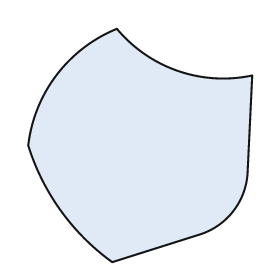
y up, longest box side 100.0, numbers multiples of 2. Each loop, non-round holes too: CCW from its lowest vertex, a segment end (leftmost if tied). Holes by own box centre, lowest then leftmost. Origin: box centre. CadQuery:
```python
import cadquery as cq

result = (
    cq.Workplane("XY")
    .moveTo(-12.0, -50.0)
    .lineTo(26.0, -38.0)
    .threePointArc((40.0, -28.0), (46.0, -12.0))
    .lineTo(48.0, 30.0)
    .threePointArc((16.0, 32.0), (-10.0, 50.0))
    .threePointArc((-36.0, 30.0), (-48.0, 0.0))
    .threePointArc((-34.0, -28.0), (-12.0, -50.0))
    .close()
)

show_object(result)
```